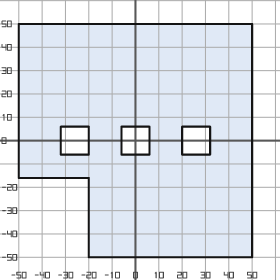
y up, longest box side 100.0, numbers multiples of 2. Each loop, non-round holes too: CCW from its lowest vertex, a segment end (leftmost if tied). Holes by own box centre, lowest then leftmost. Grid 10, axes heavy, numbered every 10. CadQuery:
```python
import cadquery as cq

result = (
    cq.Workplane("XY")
    .moveTo(-20.0, -50.0)
    .lineTo(50.0, -50.0)
    .lineTo(50.0, 50.0)
    .lineTo(-50.0, 50.0)
    .lineTo(-50.0, -16.0)
    .lineTo(-20.0, -16.0)
    .close()
    .moveTo(-32.0, -6.0)
    .lineTo(-20.0, -6.0)
    .lineTo(-20.0, 6.0)
    .lineTo(-32.0, 6.0)
    .close()
    .moveTo(-6.0, -6.0)
    .lineTo(6.0, -6.0)
    .lineTo(6.0, 6.0)
    .lineTo(-6.0, 6.0)
    .close()
    .moveTo(20.0, -6.0)
    .lineTo(32.0, -6.0)
    .lineTo(32.0, 6.0)
    .lineTo(20.0, 6.0)
    .close()
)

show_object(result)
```